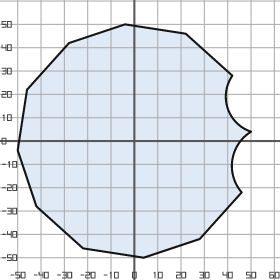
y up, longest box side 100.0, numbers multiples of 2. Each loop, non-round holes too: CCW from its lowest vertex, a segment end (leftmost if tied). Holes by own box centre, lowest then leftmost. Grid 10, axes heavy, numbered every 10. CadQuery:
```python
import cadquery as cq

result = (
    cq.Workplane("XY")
    .moveTo(4.0, -50.0)
    .lineTo(28.0, -42.0)
    .lineTo(46.0, -22.0)
    .threePointArc((42.0, -8.0), (50.0, 4.0))
    .threePointArc((40.0, 14.0), (42.0, 28.0))
    .lineTo(22.0, 46.0)
    .lineTo(-4.0, 50.0)
    .lineTo(-28.0, 42.0)
    .lineTo(-46.0, 22.0)
    .lineTo(-50.0, -4.0)
    .lineTo(-42.0, -28.0)
    .lineTo(-22.0, -46.0)
    .close()
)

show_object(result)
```